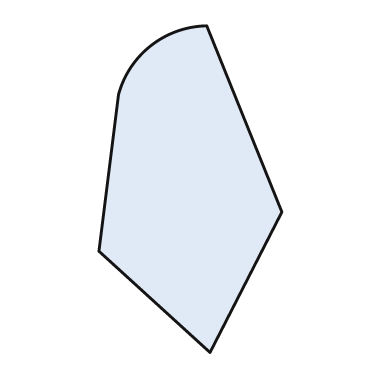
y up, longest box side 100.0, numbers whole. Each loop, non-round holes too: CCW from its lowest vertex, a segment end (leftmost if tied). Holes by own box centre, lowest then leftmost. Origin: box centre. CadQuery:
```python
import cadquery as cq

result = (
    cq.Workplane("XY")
    .moveTo(6.0, -50.0)
    .lineTo(28.0, -7.0)
    .lineTo(5.0, 50.0)
    .threePointArc((-12.0, 44.0), (-22.0, 29.0))
    .lineTo(-28.0, -19.0)
    .close()
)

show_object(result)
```